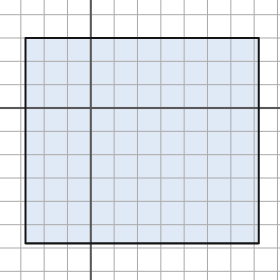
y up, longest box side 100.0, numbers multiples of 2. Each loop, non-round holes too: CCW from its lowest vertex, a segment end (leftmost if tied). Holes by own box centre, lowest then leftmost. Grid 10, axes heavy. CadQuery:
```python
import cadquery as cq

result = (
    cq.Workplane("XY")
    .moveTo(-28.0, -58.0)
    .lineTo(72.0, -58.0)
    .lineTo(72.0, 30.0)
    .lineTo(-28.0, 30.0)
    .close()
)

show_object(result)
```